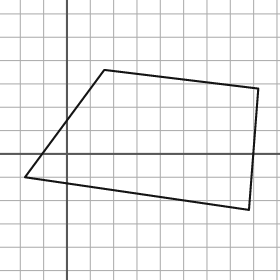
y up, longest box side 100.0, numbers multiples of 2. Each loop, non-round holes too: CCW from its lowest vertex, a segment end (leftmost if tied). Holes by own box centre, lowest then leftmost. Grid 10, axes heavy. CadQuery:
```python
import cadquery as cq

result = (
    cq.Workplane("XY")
    .moveTo(78.0, -24.0)
    .lineTo(82.0, 28.0)
    .lineTo(16.0, 36.0)
    .lineTo(-18.0, -10.0)
    .close()
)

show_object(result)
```